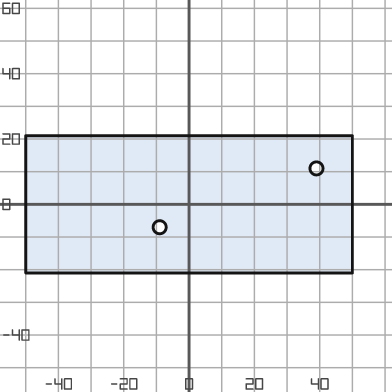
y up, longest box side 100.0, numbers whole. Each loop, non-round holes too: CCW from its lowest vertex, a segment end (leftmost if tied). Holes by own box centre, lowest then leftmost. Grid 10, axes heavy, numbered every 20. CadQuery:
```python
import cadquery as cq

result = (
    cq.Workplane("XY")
    .moveTo(-50.0, -21.0)
    .lineTo(50.0, -21.0)
    .lineTo(50.0, 21.0)
    .lineTo(-50.0, 21.0)
    .close()
    .moveTo(-9.0, -7.0)
    .circle(2.0)
    .moveTo(39.0, 11.0)
    .circle(2.0)
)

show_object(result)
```